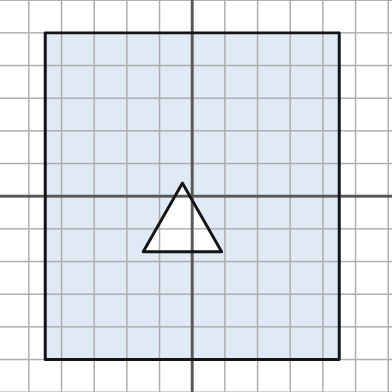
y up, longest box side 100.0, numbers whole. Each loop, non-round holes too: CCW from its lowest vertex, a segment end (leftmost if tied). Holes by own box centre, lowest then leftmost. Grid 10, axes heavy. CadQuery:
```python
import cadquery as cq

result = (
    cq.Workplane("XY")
    .moveTo(-45.0, -50.0)
    .lineTo(45.0, -50.0)
    .lineTo(45.0, 50.0)
    .lineTo(-45.0, 50.0)
    .close()
    .moveTo(-15.0, -17.0)
    .lineTo(9.0, -17.0)
    .lineTo(-3.0, 4.0)
    .close()
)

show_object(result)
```